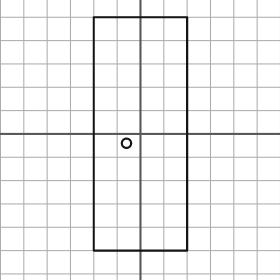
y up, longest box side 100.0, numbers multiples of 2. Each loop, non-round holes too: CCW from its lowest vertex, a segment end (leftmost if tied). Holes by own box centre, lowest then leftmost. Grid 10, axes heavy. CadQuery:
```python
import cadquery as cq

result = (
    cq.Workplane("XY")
    .moveTo(-20.0, -50.0)
    .lineTo(20.0, -50.0)
    .lineTo(20.0, 50.0)
    .lineTo(-20.0, 50.0)
    .close()
    .moveTo(-6.0, -4.0)
    .circle(2.0)
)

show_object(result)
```